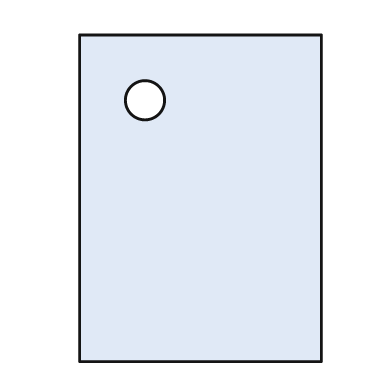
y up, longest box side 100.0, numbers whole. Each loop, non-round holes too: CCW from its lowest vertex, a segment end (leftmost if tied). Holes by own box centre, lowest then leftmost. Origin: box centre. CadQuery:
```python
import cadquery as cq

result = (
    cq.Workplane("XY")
    .moveTo(-37.0, -50.0)
    .lineTo(37.0, -50.0)
    .lineTo(37.0, 50.0)
    .lineTo(-37.0, 50.0)
    .close()
    .moveTo(-17.0, 30.0)
    .circle(6.0)
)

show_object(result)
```